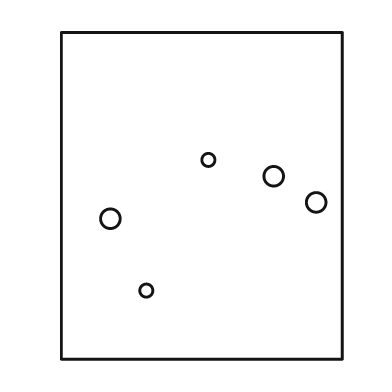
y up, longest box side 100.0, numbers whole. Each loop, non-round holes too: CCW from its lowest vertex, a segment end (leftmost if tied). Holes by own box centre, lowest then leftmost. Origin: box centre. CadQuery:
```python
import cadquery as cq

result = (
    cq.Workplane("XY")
    .moveTo(-43.0, -50.0)
    .lineTo(43.0, -50.0)
    .lineTo(43.0, 50.0)
    .lineTo(-43.0, 50.0)
    .close()
    .moveTo(-17.0, -29.0)
    .circle(2.0)
    .moveTo(-28.0, -7.0)
    .circle(3.0)
    .moveTo(35.0, -2.0)
    .circle(3.0)
    .moveTo(22.0, 6.0)
    .circle(3.0)
    .moveTo(2.0, 11.0)
    .circle(2.0)
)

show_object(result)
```